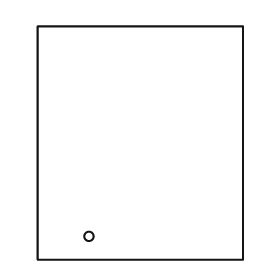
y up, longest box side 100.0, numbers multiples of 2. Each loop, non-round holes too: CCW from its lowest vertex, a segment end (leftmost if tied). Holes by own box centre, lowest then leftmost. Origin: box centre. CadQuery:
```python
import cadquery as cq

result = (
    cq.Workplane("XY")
    .moveTo(-44.0, -50.0)
    .lineTo(44.0, -50.0)
    .lineTo(44.0, 50.0)
    .lineTo(-44.0, 50.0)
    .close()
    .moveTo(-22.0, -40.0)
    .circle(2.0)
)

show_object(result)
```